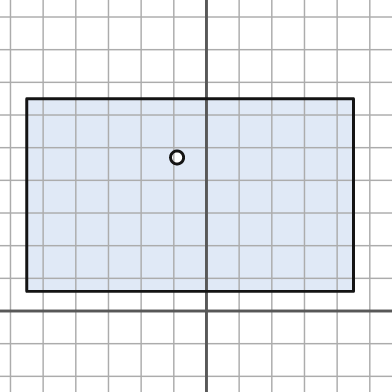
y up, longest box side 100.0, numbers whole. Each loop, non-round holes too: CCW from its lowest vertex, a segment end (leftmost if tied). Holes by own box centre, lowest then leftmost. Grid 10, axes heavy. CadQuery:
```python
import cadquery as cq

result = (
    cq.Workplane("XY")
    .moveTo(-55.0, 6.0)
    .lineTo(45.0, 6.0)
    .lineTo(45.0, 65.0)
    .lineTo(-55.0, 65.0)
    .close()
    .moveTo(-9.0, 47.0)
    .circle(2.0)
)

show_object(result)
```